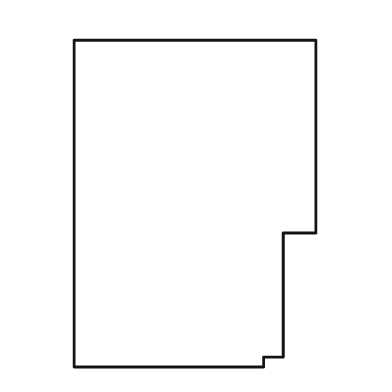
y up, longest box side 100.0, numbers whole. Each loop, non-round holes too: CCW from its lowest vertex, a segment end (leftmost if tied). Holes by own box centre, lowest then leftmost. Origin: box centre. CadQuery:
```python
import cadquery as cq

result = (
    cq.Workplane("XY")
    .moveTo(-37.0, -50.0)
    .lineTo(21.0, -50.0)
    .lineTo(21.0, -47.0)
    .lineTo(27.0, -47.0)
    .lineTo(27.0, -9.0)
    .lineTo(37.0, -9.0)
    .lineTo(37.0, 50.0)
    .lineTo(-37.0, 50.0)
    .close()
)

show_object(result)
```